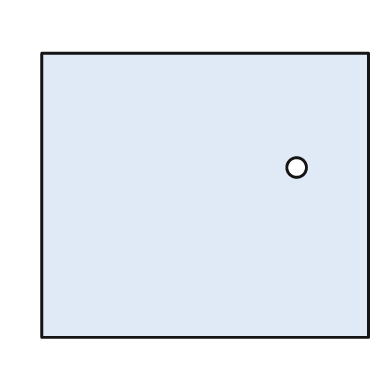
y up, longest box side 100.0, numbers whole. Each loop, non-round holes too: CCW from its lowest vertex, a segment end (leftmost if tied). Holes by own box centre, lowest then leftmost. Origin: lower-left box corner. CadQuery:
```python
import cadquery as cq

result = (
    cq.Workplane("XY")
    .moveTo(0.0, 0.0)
    .lineTo(100.0, 0.0)
    .lineTo(100.0, 87.0)
    .lineTo(0.0, 87.0)
    .close()
    .moveTo(78.0, 52.0)
    .circle(3.0)
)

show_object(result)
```